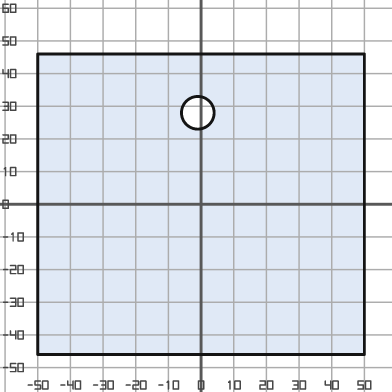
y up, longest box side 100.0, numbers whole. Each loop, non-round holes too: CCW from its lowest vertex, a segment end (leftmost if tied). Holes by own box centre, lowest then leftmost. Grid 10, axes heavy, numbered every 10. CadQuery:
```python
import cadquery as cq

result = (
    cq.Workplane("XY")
    .moveTo(-50.0, -46.0)
    .lineTo(50.0, -46.0)
    .lineTo(50.0, 46.0)
    .lineTo(-50.0, 46.0)
    .close()
    .moveTo(-1.0, 28.0)
    .circle(5.0)
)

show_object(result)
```